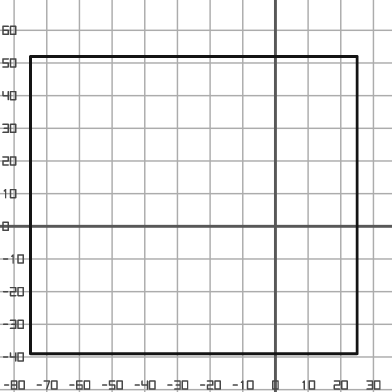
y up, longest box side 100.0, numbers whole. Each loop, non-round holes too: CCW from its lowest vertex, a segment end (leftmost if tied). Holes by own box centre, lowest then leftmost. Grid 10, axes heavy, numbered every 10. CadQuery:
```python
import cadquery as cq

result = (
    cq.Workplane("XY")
    .moveTo(-75.0, -39.0)
    .lineTo(25.0, -39.0)
    .lineTo(25.0, 52.0)
    .lineTo(-75.0, 52.0)
    .close()
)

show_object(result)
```